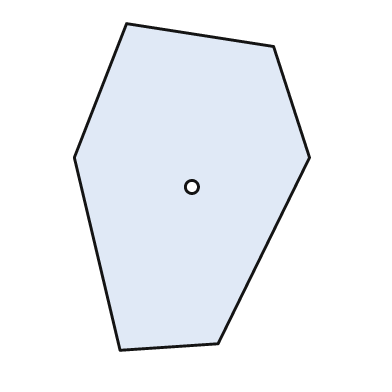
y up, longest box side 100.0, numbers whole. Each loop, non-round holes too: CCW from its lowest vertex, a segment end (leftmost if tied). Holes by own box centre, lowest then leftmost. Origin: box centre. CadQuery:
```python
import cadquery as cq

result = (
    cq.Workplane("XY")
    .moveTo(-22.0, -50.0)
    .lineTo(8.0, -48.0)
    .lineTo(36.0, 9.0)
    .lineTo(25.0, 43.0)
    .lineTo(-20.0, 50.0)
    .lineTo(-36.0, 9.0)
    .close()
    .moveTo(0.0, 0.0)
    .circle(2.0)
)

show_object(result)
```